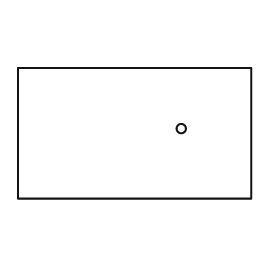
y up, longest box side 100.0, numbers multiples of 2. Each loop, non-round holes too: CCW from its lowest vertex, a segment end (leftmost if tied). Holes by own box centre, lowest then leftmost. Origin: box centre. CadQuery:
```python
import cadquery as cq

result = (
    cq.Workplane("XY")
    .moveTo(-50.0, -28.0)
    .lineTo(50.0, -28.0)
    .lineTo(50.0, 28.0)
    .lineTo(-50.0, 28.0)
    .close()
    .moveTo(20.0, 2.0)
    .circle(2.0)
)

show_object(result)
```